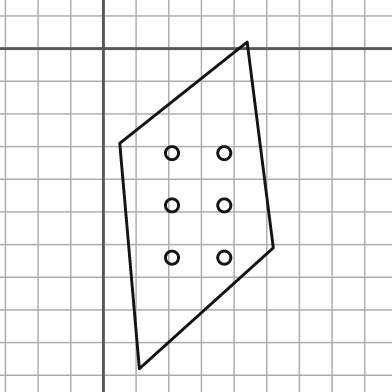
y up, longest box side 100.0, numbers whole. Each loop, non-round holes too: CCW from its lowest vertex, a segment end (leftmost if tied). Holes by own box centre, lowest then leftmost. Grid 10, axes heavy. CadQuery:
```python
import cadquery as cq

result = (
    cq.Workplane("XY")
    .moveTo(11.0, -98.0)
    .lineTo(52.0, -61.0)
    .lineTo(44.0, 2.0)
    .lineTo(5.0, -29.0)
    .close()
    .moveTo(21.0, -64.0)
    .circle(2.0)
    .moveTo(37.0, -64.0)
    .circle(2.0)
    .moveTo(21.0, -48.0)
    .circle(2.0)
    .moveTo(37.0, -48.0)
    .circle(2.0)
    .moveTo(21.0, -32.0)
    .circle(2.0)
    .moveTo(37.0, -32.0)
    .circle(2.0)
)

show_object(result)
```